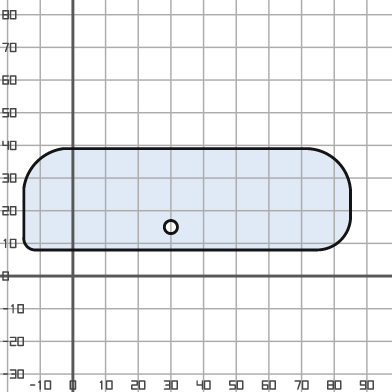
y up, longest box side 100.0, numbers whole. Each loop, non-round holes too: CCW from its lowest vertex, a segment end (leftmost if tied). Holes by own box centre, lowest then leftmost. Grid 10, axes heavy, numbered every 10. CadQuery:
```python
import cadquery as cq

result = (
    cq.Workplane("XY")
    .moveTo(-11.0, 8.0)
    .lineTo(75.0, 8.0)
    .threePointArc((82.0, 11.0), (85.0, 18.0))
    .lineTo(85.0, 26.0)
    .threePointArc((81.0, 35.0), (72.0, 39.0))
    .lineTo(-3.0, 39.0)
    .threePointArc((-11.0, 35.0), (-15.0, 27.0))
    .lineTo(-15.0, 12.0)
    .threePointArc((-14.0, 9.0), (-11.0, 8.0))
    .close()
    .moveTo(30.0, 15.0)
    .circle(2.0)
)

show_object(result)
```